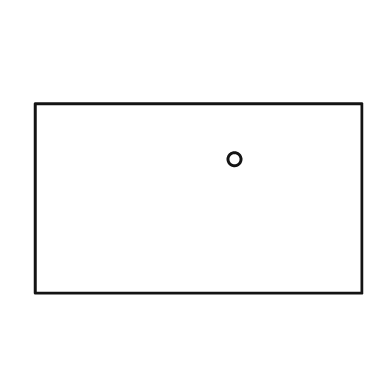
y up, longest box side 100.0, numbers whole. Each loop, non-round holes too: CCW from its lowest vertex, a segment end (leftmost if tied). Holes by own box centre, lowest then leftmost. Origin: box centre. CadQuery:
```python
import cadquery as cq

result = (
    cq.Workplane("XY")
    .moveTo(-50.0, -29.0)
    .lineTo(50.0, -29.0)
    .lineTo(50.0, 29.0)
    .lineTo(-50.0, 29.0)
    .close()
    .moveTo(11.0, 12.0)
    .circle(2.0)
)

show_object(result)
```